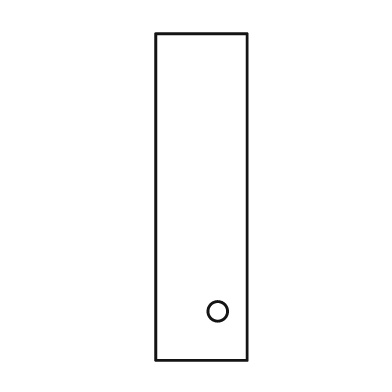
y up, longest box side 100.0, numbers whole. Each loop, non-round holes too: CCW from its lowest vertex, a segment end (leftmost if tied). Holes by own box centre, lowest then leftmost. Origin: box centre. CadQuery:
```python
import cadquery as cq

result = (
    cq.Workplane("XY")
    .moveTo(-14.0, -50.0)
    .lineTo(14.0, -50.0)
    .lineTo(14.0, 50.0)
    .lineTo(-14.0, 50.0)
    .close()
    .moveTo(5.0, -35.0)
    .circle(3.0)
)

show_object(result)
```